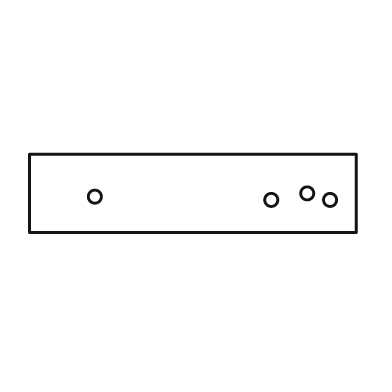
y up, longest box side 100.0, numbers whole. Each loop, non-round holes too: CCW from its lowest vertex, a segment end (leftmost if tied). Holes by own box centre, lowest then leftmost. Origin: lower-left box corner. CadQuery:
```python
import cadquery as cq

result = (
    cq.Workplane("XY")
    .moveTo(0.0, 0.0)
    .lineTo(100.0, 0.0)
    .lineTo(100.0, 24.0)
    .lineTo(0.0, 24.0)
    .close()
    .moveTo(74.0, 10.0)
    .circle(2.0)
    .moveTo(92.0, 10.0)
    .circle(2.0)
    .moveTo(20.0, 11.0)
    .circle(2.0)
    .moveTo(85.0, 12.0)
    .circle(2.0)
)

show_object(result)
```